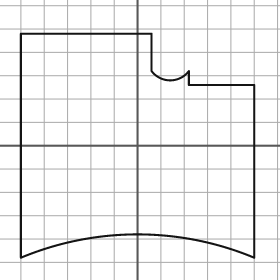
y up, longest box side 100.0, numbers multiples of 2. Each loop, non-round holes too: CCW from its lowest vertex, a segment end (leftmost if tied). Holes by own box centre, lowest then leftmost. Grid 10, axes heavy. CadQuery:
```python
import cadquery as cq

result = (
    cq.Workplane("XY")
    .moveTo(-50.0, -48.0)
    .threePointArc((0.0, -38.0), (50.0, -48.0))
    .lineTo(50.0, 26.0)
    .lineTo(22.0, 26.0)
    .lineTo(22.0, 32.0)
    .threePointArc((14.0, 28.0), (6.0, 32.0))
    .lineTo(6.0, 48.0)
    .lineTo(-50.0, 48.0)
    .close()
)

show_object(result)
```